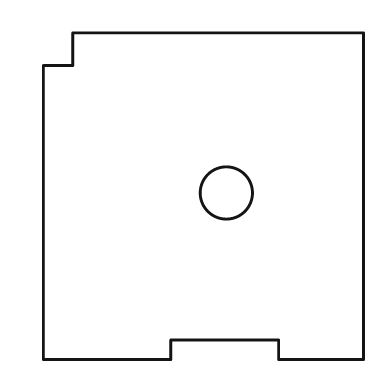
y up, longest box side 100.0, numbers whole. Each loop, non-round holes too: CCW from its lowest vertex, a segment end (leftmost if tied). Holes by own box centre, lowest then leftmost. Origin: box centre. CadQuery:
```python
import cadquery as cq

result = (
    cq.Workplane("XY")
    .moveTo(-49.0, -50.0)
    .lineTo(-10.0, -50.0)
    .lineTo(-10.0, -44.0)
    .lineTo(23.0, -44.0)
    .lineTo(23.0, -50.0)
    .lineTo(49.0, -50.0)
    .lineTo(49.0, 50.0)
    .lineTo(-40.0, 50.0)
    .lineTo(-40.0, 40.0)
    .lineTo(-49.0, 40.0)
    .close()
    .moveTo(7.0, 1.0)
    .circle(8.0)
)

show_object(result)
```